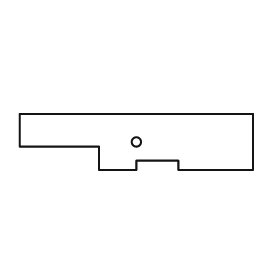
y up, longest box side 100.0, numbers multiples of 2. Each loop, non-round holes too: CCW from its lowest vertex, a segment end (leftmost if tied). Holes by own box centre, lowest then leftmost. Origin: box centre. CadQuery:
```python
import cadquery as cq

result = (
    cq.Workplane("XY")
    .moveTo(-16.0, -12.0)
    .lineTo(0.0, -12.0)
    .lineTo(0.0, -8.0)
    .lineTo(18.0, -8.0)
    .lineTo(18.0, -12.0)
    .lineTo(50.0, -12.0)
    .lineTo(50.0, 12.0)
    .lineTo(-50.0, 12.0)
    .lineTo(-50.0, -2.0)
    .lineTo(-16.0, -2.0)
    .close()
    .moveTo(0.0, 0.0)
    .circle(2.0)
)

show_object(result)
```